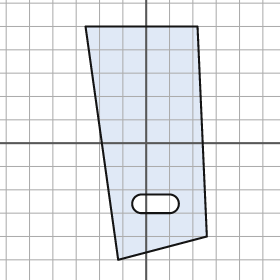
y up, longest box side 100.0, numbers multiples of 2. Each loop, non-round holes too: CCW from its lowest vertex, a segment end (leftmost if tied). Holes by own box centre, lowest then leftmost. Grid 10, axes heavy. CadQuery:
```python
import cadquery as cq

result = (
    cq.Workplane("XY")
    .moveTo(-12.0, -50.0)
    .lineTo(26.0, -40.0)
    .lineTo(22.0, 50.0)
    .lineTo(-26.0, 50.0)
    .close()
    .moveTo(-2.0, -30.0)
    .lineTo(10.0, -30.0)
    .threePointArc((14.0, -26.0), (10.0, -22.0))
    .lineTo(-2.0, -22.0)
    .threePointArc((-6.0, -26.0), (-2.0, -30.0))
    .close()
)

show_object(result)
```